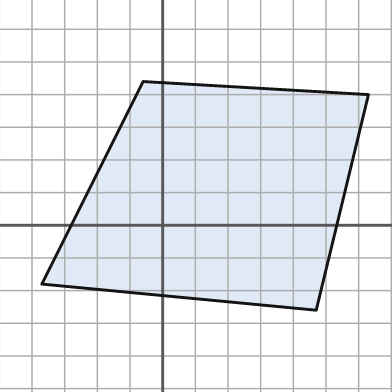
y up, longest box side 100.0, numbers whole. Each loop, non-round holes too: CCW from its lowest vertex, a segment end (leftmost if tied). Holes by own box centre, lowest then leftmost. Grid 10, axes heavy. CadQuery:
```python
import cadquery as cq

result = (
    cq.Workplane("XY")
    .moveTo(47.0, -26.0)
    .lineTo(63.0, 40.0)
    .lineTo(-6.0, 44.0)
    .lineTo(-37.0, -18.0)
    .close()
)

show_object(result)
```